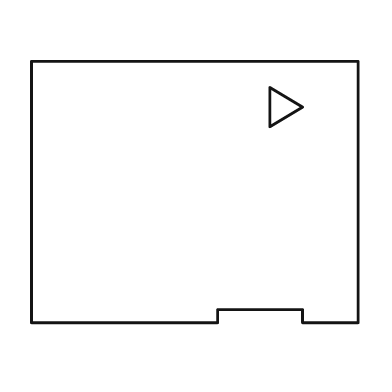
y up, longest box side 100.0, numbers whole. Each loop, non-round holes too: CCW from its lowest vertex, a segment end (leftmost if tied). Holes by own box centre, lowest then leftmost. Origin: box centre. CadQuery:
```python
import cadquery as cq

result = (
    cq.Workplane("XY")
    .moveTo(-50.0, -40.0)
    .lineTo(7.0, -40.0)
    .lineTo(7.0, -36.0)
    .lineTo(33.0, -36.0)
    .lineTo(33.0, -40.0)
    .lineTo(50.0, -40.0)
    .lineTo(50.0, 40.0)
    .lineTo(-50.0, 40.0)
    .close()
    .moveTo(23.0, 20.0)
    .lineTo(33.0, 26.0)
    .lineTo(23.0, 32.0)
    .close()
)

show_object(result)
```